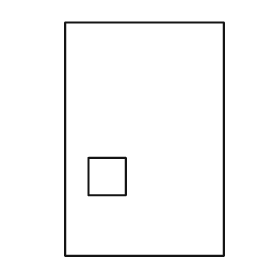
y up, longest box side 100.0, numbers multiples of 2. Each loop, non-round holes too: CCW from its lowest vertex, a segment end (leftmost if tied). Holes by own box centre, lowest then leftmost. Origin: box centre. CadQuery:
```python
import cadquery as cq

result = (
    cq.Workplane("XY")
    .moveTo(-34.0, -50.0)
    .lineTo(34.0, -50.0)
    .lineTo(34.0, 50.0)
    .lineTo(-34.0, 50.0)
    .close()
    .moveTo(-24.0, -24.0)
    .lineTo(-8.0, -24.0)
    .lineTo(-8.0, -8.0)
    .lineTo(-24.0, -8.0)
    .close()
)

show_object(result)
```